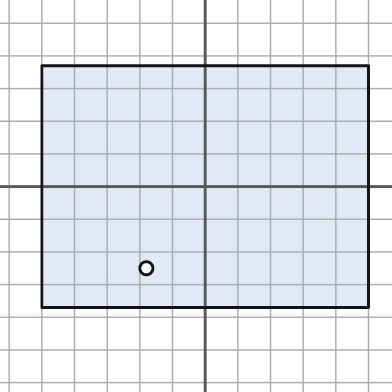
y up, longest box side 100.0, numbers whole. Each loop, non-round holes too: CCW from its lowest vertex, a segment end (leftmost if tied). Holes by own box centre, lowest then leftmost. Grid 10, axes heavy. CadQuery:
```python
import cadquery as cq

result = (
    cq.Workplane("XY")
    .moveTo(-50.0, -37.0)
    .lineTo(50.0, -37.0)
    .lineTo(50.0, 37.0)
    .lineTo(-50.0, 37.0)
    .close()
    .moveTo(-18.0, -25.0)
    .circle(2.0)
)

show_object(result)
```